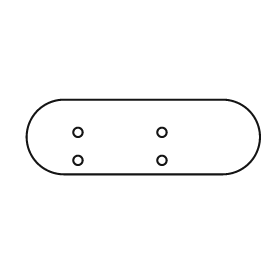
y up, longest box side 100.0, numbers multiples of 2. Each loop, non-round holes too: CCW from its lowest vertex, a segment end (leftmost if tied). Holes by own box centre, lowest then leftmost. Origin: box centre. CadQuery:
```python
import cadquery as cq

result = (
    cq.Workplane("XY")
    .moveTo(-34.0, -16.0)
    .lineTo(34.0, -16.0)
    .threePointArc((50.0, 0.0), (34.0, 16.0))
    .lineTo(-34.0, 16.0)
    .threePointArc((-50.0, 0.0), (-34.0, -16.0))
    .close()
    .moveTo(-28.0, -10.0)
    .circle(2.0)
    .moveTo(8.0, -10.0)
    .circle(2.0)
    .moveTo(-28.0, 2.0)
    .circle(2.0)
    .moveTo(8.0, 2.0)
    .circle(2.0)
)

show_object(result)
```